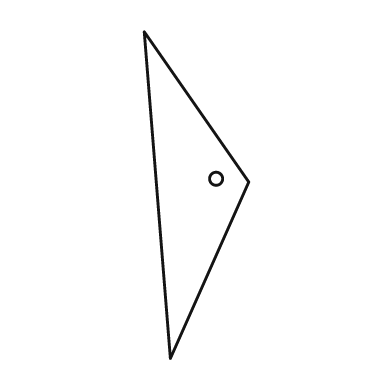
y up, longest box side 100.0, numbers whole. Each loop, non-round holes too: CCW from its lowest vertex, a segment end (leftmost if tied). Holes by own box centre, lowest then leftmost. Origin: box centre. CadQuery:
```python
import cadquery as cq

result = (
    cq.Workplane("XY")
    .moveTo(-8.0, -50.0)
    .lineTo(16.0, 4.0)
    .lineTo(-16.0, 50.0)
    .close()
    .moveTo(6.0, 5.0)
    .circle(2.0)
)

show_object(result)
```